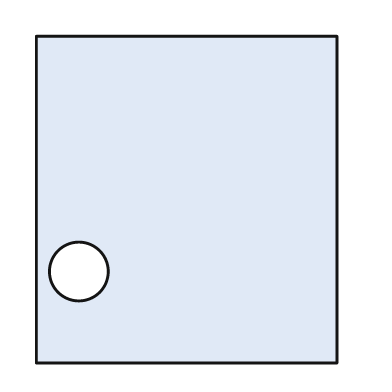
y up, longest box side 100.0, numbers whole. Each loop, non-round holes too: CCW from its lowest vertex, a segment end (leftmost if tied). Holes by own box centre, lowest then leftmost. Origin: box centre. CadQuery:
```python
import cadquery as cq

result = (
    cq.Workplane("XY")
    .moveTo(-46.0, -50.0)
    .lineTo(46.0, -50.0)
    .lineTo(46.0, 50.0)
    .lineTo(-46.0, 50.0)
    .close()
    .moveTo(-33.0, -22.0)
    .circle(9.0)
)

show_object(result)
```